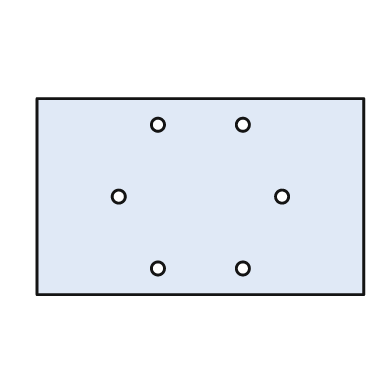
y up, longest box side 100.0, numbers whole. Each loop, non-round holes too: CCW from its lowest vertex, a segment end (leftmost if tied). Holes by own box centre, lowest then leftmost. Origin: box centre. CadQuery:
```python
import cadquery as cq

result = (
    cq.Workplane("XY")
    .moveTo(-50.0, -30.0)
    .lineTo(50.0, -30.0)
    .lineTo(50.0, 30.0)
    .lineTo(-50.0, 30.0)
    .close()
    .moveTo(-13.0, -22.0)
    .circle(2.0)
    .moveTo(13.0, -22.0)
    .circle(2.0)
    .moveTo(-25.0, 0.0)
    .circle(2.0)
    .moveTo(25.0, 0.0)
    .circle(2.0)
    .moveTo(-13.0, 22.0)
    .circle(2.0)
    .moveTo(13.0, 22.0)
    .circle(2.0)
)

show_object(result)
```